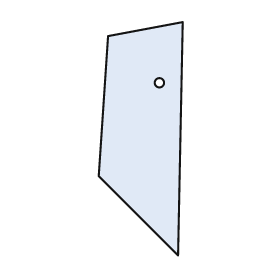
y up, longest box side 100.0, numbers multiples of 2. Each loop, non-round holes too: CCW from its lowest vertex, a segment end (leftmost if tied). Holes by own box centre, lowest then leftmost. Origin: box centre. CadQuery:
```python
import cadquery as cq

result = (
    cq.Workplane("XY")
    .moveTo(16.0, -50.0)
    .lineTo(18.0, 50.0)
    .lineTo(-14.0, 44.0)
    .lineTo(-18.0, -16.0)
    .close()
    .moveTo(8.0, 24.0)
    .circle(2.0)
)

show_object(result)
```